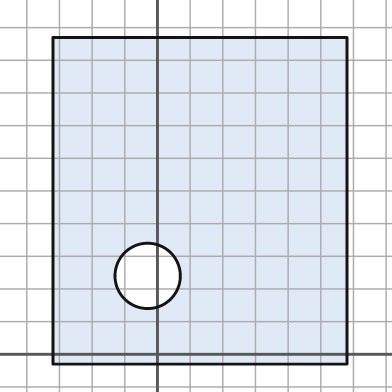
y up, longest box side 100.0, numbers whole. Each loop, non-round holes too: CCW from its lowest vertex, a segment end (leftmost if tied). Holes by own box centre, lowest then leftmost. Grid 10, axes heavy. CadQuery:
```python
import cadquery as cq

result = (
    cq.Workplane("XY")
    .moveTo(-32.0, -3.0)
    .lineTo(58.0, -3.0)
    .lineTo(58.0, 97.0)
    .lineTo(-32.0, 97.0)
    .close()
    .moveTo(-3.0, 24.0)
    .circle(10.0)
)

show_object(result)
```